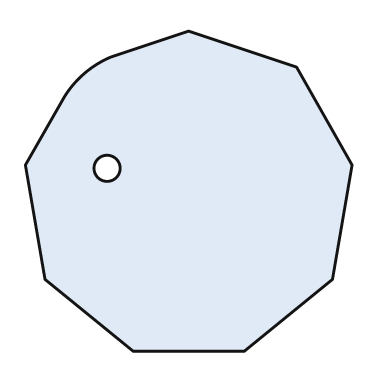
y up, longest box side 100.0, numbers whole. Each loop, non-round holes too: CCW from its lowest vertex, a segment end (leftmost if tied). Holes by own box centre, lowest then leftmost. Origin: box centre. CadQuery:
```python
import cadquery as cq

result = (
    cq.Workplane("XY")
    .moveTo(-17.0, -49.0)
    .lineTo(17.0, -49.0)
    .lineTo(44.0, -27.0)
    .lineTo(50.0, 8.0)
    .lineTo(33.0, 38.0)
    .lineTo(0.0, 49.0)
    .lineTo(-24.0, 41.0)
    .threePointArc((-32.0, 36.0), (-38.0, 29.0))
    .lineTo(-50.0, 8.0)
    .lineTo(-44.0, -27.0)
    .close()
    .moveTo(-25.0, 7.0)
    .circle(4.0)
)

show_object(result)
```